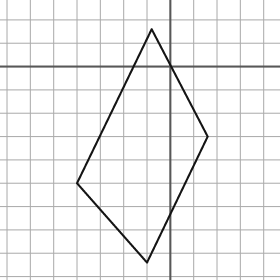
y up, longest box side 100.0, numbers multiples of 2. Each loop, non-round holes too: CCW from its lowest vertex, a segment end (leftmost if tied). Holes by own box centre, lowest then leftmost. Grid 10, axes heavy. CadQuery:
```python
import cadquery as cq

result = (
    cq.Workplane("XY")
    .moveTo(-10.0, -84.0)
    .lineTo(16.0, -30.0)
    .lineTo(-8.0, 16.0)
    .lineTo(-40.0, -50.0)
    .close()
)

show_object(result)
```